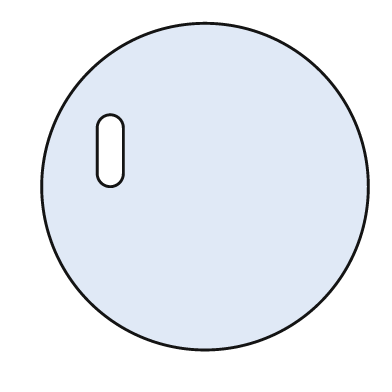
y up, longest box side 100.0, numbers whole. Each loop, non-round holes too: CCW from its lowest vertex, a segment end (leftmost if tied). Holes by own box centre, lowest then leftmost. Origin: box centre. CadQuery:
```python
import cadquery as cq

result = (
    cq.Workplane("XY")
    .moveTo(0.0, 0.0)
    .circle(50.0)
    .moveTo(-33.0, 4.0)
    .threePointArc((-29.0, 0.0), (-25.0, 4.0))
    .lineTo(-25.0, 18.0)
    .threePointArc((-29.0, 22.0), (-33.0, 18.0))
    .close()
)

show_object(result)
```